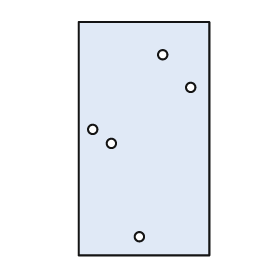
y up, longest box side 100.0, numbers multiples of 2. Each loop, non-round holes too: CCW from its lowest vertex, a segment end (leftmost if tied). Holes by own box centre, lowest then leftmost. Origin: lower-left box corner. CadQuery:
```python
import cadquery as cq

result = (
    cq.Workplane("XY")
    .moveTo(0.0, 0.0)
    .lineTo(56.0, 0.0)
    .lineTo(56.0, 100.0)
    .lineTo(0.0, 100.0)
    .close()
    .moveTo(26.0, 8.0)
    .circle(2.0)
    .moveTo(14.0, 48.0)
    .circle(2.0)
    .moveTo(6.0, 54.0)
    .circle(2.0)
    .moveTo(48.0, 72.0)
    .circle(2.0)
    .moveTo(36.0, 86.0)
    .circle(2.0)
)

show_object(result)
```